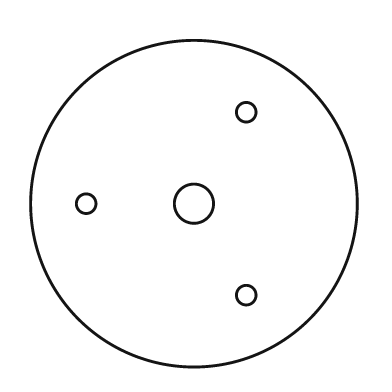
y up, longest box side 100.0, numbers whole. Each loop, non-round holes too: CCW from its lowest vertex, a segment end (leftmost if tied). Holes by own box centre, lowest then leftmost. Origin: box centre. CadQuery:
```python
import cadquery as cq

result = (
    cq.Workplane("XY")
    .moveTo(0.0, 0.0)
    .circle(50.0)
    .moveTo(16.0, -28.0)
    .circle(3.0)
    .moveTo(-33.0, 0.0)
    .circle(3.0)
    .moveTo(0.0, 0.0)
    .circle(6.0)
    .moveTo(16.0, 28.0)
    .circle(3.0)
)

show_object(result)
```